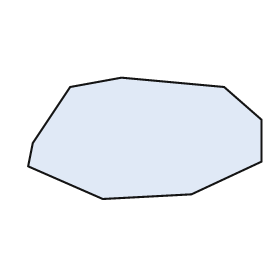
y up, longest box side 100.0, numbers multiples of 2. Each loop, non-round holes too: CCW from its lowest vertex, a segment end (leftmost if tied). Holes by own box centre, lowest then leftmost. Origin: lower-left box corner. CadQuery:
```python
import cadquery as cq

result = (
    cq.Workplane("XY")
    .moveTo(32.0, 0.0)
    .lineTo(70.0, 2.0)
    .lineTo(100.0, 16.0)
    .lineTo(100.0, 34.0)
    .lineTo(84.0, 48.0)
    .lineTo(40.0, 52.0)
    .lineTo(18.0, 48.0)
    .lineTo(2.0, 24.0)
    .lineTo(0.0, 14.0)
    .close()
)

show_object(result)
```